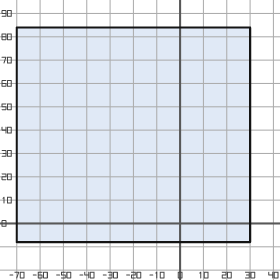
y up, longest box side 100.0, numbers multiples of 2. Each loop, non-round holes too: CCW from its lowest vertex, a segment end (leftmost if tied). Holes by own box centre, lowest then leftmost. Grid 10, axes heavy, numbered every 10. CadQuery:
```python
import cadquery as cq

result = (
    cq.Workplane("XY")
    .moveTo(-70.0, -8.0)
    .lineTo(30.0, -8.0)
    .lineTo(30.0, 84.0)
    .lineTo(-70.0, 84.0)
    .close()
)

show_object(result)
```